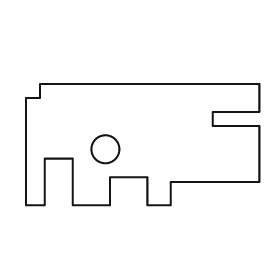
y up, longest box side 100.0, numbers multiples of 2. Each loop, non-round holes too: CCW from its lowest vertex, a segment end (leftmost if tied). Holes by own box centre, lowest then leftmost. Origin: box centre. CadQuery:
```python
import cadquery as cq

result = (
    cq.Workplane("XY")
    .moveTo(-50.0, -26.0)
    .lineTo(-42.0, -26.0)
    .lineTo(-42.0, -6.0)
    .lineTo(-30.0, -6.0)
    .lineTo(-30.0, -26.0)
    .lineTo(-14.0, -26.0)
    .lineTo(-14.0, -14.0)
    .lineTo(2.0, -14.0)
    .lineTo(2.0, -26.0)
    .lineTo(12.0, -26.0)
    .lineTo(12.0, -16.0)
    .lineTo(50.0, -16.0)
    .lineTo(50.0, 8.0)
    .lineTo(30.0, 8.0)
    .lineTo(30.0, 14.0)
    .lineTo(50.0, 14.0)
    .lineTo(50.0, 26.0)
    .lineTo(-44.0, 26.0)
    .lineTo(-44.0, 20.0)
    .lineTo(-50.0, 20.0)
    .close()
    .moveTo(-16.0, -2.0)
    .circle(6.0)
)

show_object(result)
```